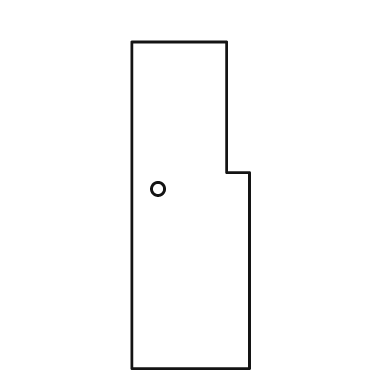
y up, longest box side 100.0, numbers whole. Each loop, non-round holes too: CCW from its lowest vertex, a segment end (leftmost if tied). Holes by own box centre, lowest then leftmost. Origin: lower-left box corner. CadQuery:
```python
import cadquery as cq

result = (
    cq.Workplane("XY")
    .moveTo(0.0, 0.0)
    .lineTo(36.0, 0.0)
    .lineTo(36.0, 60.0)
    .lineTo(29.0, 60.0)
    .lineTo(29.0, 100.0)
    .lineTo(0.0, 100.0)
    .close()
    .moveTo(8.0, 55.0)
    .circle(2.0)
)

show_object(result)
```